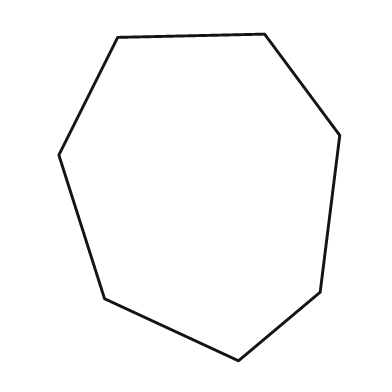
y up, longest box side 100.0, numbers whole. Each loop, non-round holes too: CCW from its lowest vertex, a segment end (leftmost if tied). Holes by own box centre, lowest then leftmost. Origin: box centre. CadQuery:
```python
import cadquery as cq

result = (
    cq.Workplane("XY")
    .moveTo(12.0, -50.0)
    .lineTo(37.0, -29.0)
    .lineTo(43.0, 19.0)
    .lineTo(20.0, 50.0)
    .lineTo(-25.0, 49.0)
    .lineTo(-43.0, 13.0)
    .lineTo(-29.0, -31.0)
    .close()
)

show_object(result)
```